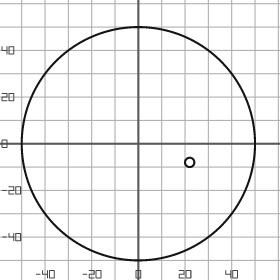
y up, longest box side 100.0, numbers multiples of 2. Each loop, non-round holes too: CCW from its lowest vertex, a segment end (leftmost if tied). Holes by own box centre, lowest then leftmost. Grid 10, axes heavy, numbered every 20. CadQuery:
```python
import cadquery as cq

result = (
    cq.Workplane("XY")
    .moveTo(0.0, 0.0)
    .circle(50.0)
    .moveTo(22.0, -8.0)
    .circle(2.0)
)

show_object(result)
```